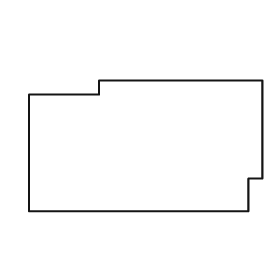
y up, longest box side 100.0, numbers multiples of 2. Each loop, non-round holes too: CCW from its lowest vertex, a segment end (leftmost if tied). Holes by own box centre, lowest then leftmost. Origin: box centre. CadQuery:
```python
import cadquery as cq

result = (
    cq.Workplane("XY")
    .moveTo(-50.0, -28.0)
    .lineTo(44.0, -28.0)
    .lineTo(44.0, -14.0)
    .lineTo(50.0, -14.0)
    .lineTo(50.0, 28.0)
    .lineTo(-20.0, 28.0)
    .lineTo(-20.0, 22.0)
    .lineTo(-50.0, 22.0)
    .close()
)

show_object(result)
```